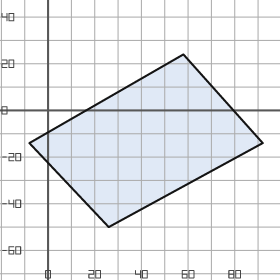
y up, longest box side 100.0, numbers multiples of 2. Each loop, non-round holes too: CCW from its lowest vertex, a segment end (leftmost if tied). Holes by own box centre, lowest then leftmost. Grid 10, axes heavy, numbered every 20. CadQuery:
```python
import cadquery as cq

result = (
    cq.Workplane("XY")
    .moveTo(26.0, -50.0)
    .lineTo(92.0, -14.0)
    .lineTo(58.0, 24.0)
    .lineTo(-8.0, -14.0)
    .close()
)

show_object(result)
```